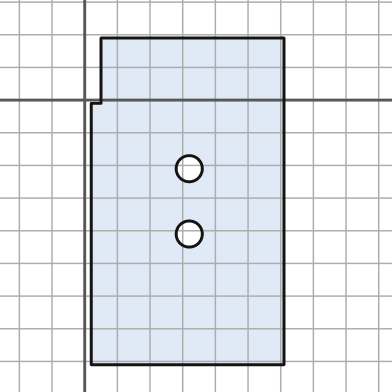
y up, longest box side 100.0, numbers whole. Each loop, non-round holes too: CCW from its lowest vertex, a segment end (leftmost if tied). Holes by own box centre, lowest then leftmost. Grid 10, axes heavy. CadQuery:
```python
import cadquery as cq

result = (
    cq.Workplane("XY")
    .moveTo(2.0, -81.0)
    .lineTo(61.0, -81.0)
    .lineTo(61.0, 19.0)
    .lineTo(5.0, 19.0)
    .lineTo(5.0, -1.0)
    .lineTo(2.0, -1.0)
    .close()
    .moveTo(32.0, -41.0)
    .circle(4.0)
    .moveTo(32.0, -21.0)
    .circle(4.0)
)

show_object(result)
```